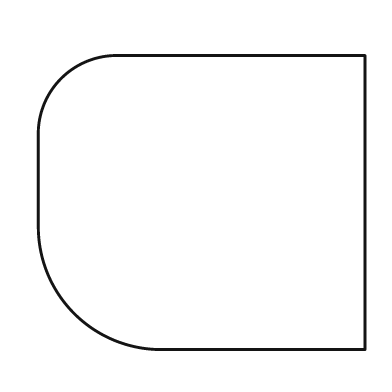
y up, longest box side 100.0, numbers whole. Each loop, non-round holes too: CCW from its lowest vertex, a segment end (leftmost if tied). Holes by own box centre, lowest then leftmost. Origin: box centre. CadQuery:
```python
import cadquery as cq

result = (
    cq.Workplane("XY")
    .moveTo(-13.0, -45.0)
    .lineTo(50.0, -45.0)
    .lineTo(50.0, 45.0)
    .lineTo(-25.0, 45.0)
    .threePointArc((-43.0, 38.0), (-50.0, 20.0))
    .lineTo(-50.0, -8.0)
    .threePointArc((-39.0, -34.0), (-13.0, -45.0))
    .close()
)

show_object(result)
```